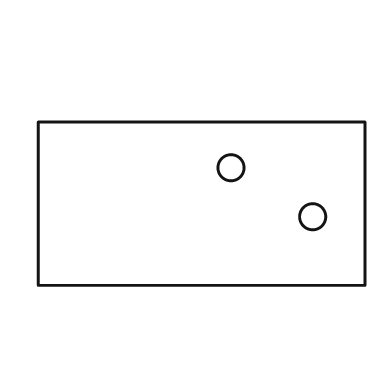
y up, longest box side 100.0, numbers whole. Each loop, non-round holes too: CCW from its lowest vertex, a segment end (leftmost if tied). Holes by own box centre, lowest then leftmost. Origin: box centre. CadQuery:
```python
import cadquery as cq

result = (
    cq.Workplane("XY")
    .moveTo(-50.0, -25.0)
    .lineTo(50.0, -25.0)
    .lineTo(50.0, 25.0)
    .lineTo(-50.0, 25.0)
    .close()
    .moveTo(34.0, -4.0)
    .circle(4.0)
    .moveTo(9.0, 11.0)
    .circle(4.0)
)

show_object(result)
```